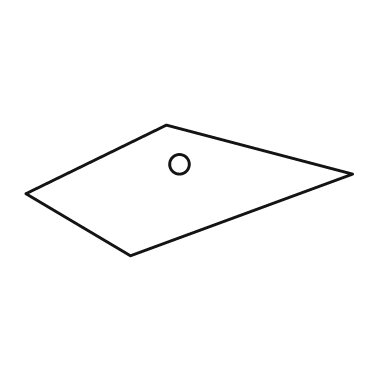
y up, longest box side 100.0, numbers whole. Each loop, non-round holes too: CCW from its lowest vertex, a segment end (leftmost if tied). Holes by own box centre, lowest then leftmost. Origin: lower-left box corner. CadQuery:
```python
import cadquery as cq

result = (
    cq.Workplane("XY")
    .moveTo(32.0, 0.0)
    .lineTo(100.0, 25.0)
    .lineTo(43.0, 40.0)
    .lineTo(0.0, 19.0)
    .close()
    .moveTo(47.0, 28.0)
    .circle(3.0)
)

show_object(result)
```